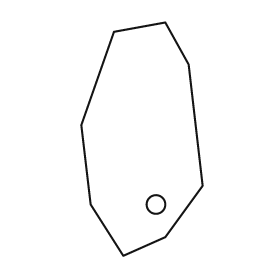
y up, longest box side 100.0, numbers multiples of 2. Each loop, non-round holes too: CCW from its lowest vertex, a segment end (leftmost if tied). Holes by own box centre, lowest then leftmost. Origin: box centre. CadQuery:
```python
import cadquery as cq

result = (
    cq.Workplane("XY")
    .moveTo(-8.0, -50.0)
    .lineTo(10.0, -42.0)
    .lineTo(26.0, -20.0)
    .lineTo(20.0, 32.0)
    .lineTo(10.0, 50.0)
    .lineTo(-12.0, 46.0)
    .lineTo(-26.0, 6.0)
    .lineTo(-22.0, -28.0)
    .close()
    .moveTo(6.0, -28.0)
    .circle(4.0)
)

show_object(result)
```